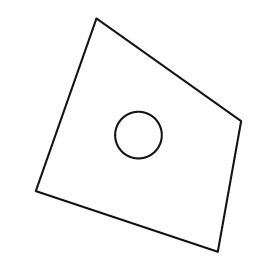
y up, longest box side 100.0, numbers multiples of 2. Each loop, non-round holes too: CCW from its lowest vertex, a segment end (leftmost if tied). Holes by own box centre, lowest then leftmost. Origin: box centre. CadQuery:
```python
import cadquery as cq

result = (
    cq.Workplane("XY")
    .moveTo(34.0, -50.0)
    .lineTo(44.0, 6.0)
    .lineTo(-18.0, 50.0)
    .lineTo(-44.0, -24.0)
    .close()
    .moveTo(0.0, 0.0)
    .circle(10.0)
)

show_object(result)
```